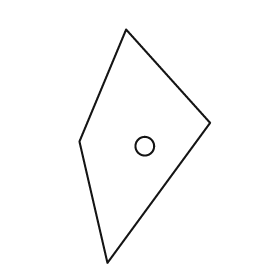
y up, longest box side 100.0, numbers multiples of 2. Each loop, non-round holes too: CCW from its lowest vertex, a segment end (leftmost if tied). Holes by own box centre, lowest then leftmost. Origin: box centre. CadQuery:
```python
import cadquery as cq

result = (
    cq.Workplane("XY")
    .moveTo(-16.0, -50.0)
    .lineTo(28.0, 10.0)
    .lineTo(-8.0, 50.0)
    .lineTo(-28.0, 2.0)
    .close()
    .moveTo(0.0, 0.0)
    .circle(4.0)
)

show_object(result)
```